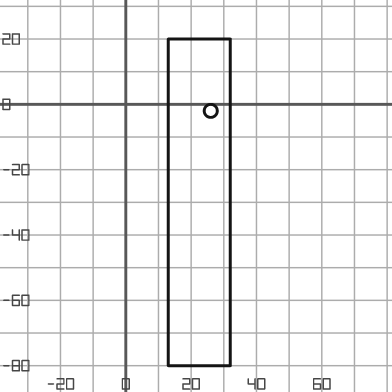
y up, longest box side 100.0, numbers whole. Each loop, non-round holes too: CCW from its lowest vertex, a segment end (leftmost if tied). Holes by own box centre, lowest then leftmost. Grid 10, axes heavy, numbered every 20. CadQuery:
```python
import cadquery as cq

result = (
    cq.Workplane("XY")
    .moveTo(13.0, -80.0)
    .lineTo(32.0, -80.0)
    .lineTo(32.0, 20.0)
    .lineTo(13.0, 20.0)
    .close()
    .moveTo(26.0, -2.0)
    .circle(2.0)
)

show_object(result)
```